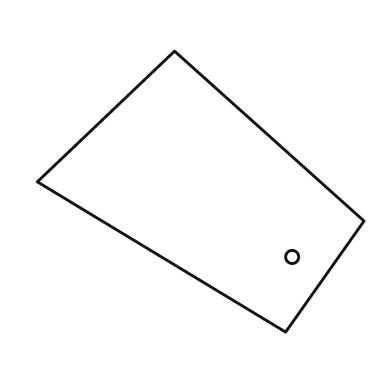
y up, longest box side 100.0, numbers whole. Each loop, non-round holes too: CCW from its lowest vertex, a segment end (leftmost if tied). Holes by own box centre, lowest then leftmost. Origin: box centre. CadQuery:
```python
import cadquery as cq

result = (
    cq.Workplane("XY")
    .moveTo(26.0, -43.0)
    .lineTo(50.0, -9.0)
    .lineTo(-8.0, 43.0)
    .lineTo(-50.0, 3.0)
    .close()
    .moveTo(28.0, -20.0)
    .circle(2.0)
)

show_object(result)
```